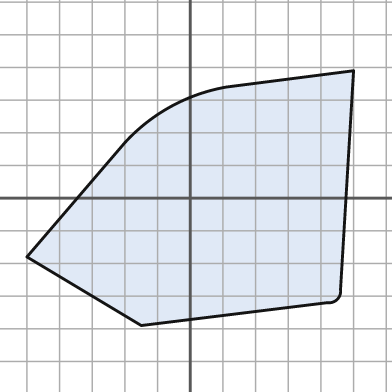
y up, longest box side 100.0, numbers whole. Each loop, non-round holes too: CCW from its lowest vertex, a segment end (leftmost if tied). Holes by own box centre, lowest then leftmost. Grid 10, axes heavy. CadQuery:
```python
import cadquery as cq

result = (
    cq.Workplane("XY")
    .moveTo(-15.0, -39.0)
    .lineTo(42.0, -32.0)
    .threePointArc((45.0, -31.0), (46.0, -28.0))
    .lineTo(50.0, 39.0)
    .lineTo(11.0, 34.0)
    .threePointArc((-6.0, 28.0), (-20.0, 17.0))
    .lineTo(-50.0, -18.0)
    .close()
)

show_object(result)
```